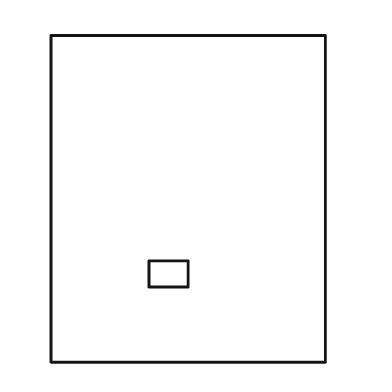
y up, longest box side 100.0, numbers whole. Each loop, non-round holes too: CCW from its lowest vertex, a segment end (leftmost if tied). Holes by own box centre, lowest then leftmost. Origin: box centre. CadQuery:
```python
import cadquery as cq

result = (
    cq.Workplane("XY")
    .moveTo(-42.0, -50.0)
    .lineTo(42.0, -50.0)
    .lineTo(42.0, 50.0)
    .lineTo(-42.0, 50.0)
    .close()
    .moveTo(-12.0, -27.0)
    .lineTo(0.0, -27.0)
    .lineTo(0.0, -19.0)
    .lineTo(-12.0, -19.0)
    .close()
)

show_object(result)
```